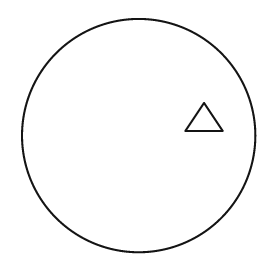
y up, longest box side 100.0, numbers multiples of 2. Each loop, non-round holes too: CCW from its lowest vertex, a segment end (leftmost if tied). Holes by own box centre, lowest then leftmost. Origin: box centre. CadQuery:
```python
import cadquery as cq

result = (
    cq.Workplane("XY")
    .moveTo(0.0, 0.0)
    .circle(50.0)
    .moveTo(20.0, 2.0)
    .lineTo(36.0, 2.0)
    .lineTo(28.0, 14.0)
    .close()
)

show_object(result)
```